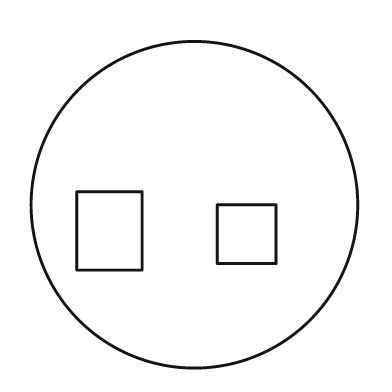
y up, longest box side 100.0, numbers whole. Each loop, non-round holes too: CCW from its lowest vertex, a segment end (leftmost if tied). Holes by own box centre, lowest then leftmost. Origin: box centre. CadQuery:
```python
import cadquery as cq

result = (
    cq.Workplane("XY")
    .moveTo(0.0, 0.0)
    .circle(50.0)
    .moveTo(7.0, -18.0)
    .lineTo(25.0, -18.0)
    .lineTo(25.0, 0.0)
    .lineTo(7.0, 0.0)
    .close()
    .moveTo(-36.0, -20.0)
    .lineTo(-16.0, -20.0)
    .lineTo(-16.0, 4.0)
    .lineTo(-36.0, 4.0)
    .close()
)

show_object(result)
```